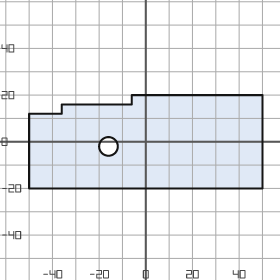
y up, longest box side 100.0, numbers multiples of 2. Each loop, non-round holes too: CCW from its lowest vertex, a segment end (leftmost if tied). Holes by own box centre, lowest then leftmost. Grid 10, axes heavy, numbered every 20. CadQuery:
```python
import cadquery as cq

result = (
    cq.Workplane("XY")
    .moveTo(-50.0, -20.0)
    .lineTo(50.0, -20.0)
    .lineTo(50.0, 20.0)
    .lineTo(-6.0, 20.0)
    .lineTo(-6.0, 16.0)
    .lineTo(-36.0, 16.0)
    .lineTo(-36.0, 12.0)
    .lineTo(-50.0, 12.0)
    .close()
    .moveTo(-16.0, -2.0)
    .circle(4.0)
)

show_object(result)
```